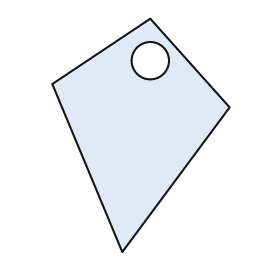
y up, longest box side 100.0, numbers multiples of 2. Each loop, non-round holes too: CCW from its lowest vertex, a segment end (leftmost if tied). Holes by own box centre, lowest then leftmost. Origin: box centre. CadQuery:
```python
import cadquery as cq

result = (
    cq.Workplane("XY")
    .moveTo(-8.0, -50.0)
    .lineTo(38.0, 12.0)
    .lineTo(4.0, 50.0)
    .lineTo(-38.0, 22.0)
    .close()
    .moveTo(4.0, 32.0)
    .circle(8.0)
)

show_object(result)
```